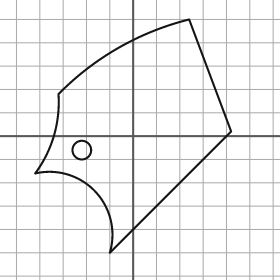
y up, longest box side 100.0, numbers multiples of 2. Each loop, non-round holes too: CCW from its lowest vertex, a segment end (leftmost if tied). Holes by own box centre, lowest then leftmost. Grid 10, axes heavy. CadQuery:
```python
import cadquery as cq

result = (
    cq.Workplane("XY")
    .moveTo(-10.0, -50.0)
    .lineTo(42.0, 2.0)
    .lineTo(24.0, 50.0)
    .threePointArc((-6.0, 38.0), (-32.0, 18.0))
    .threePointArc((-34.0, 0.0), (-42.0, -16.0))
    .threePointArc((-16.0, -24.0), (-10.0, -50.0))
    .close()
    .moveTo(-22.0, -6.0)
    .circle(4.0)
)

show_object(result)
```